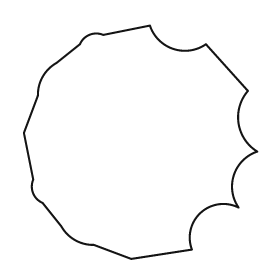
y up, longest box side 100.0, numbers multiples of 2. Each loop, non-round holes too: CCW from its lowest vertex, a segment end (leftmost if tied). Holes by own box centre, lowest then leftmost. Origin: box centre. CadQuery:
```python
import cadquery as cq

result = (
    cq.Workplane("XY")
    .moveTo(-4.0, -50.0)
    .lineTo(22.0, -46.0)
    .threePointArc((26.0, -30.0), (42.0, -28.0))
    .threePointArc((40.0, -14.0), (50.0, -4.0))
    .threePointArc((42.0, 8.0), (46.0, 22.0))
    .lineTo(28.0, 42.0)
    .threePointArc((14.0, 40.0), (4.0, 50.0))
    .lineTo(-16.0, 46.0)
    .threePointArc((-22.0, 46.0), (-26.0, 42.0))
    .lineTo(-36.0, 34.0)
    .threePointArc((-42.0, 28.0), (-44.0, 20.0))
    .lineTo(-50.0, 4.0)
    .lineTo(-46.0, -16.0)
    .threePointArc((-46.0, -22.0), (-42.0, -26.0))
    .lineTo(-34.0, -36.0)
    .threePointArc((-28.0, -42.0), (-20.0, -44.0))
    .close()
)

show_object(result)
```